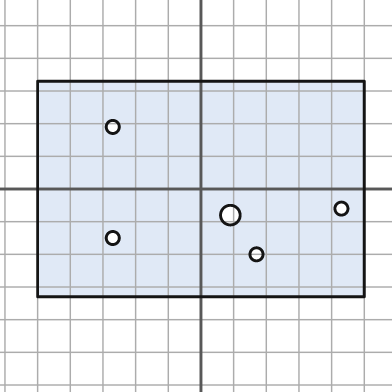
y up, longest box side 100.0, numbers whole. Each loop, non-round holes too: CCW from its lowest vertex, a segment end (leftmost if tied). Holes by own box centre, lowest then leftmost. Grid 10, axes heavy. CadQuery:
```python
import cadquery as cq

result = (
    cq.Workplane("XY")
    .moveTo(-50.0, -33.0)
    .lineTo(50.0, -33.0)
    .lineTo(50.0, 33.0)
    .lineTo(-50.0, 33.0)
    .close()
    .moveTo(17.0, -20.0)
    .circle(2.0)
    .moveTo(-27.0, -15.0)
    .circle(2.0)
    .moveTo(9.0, -8.0)
    .circle(3.0)
    .moveTo(43.0, -6.0)
    .circle(2.0)
    .moveTo(-27.0, 19.0)
    .circle(2.0)
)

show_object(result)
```